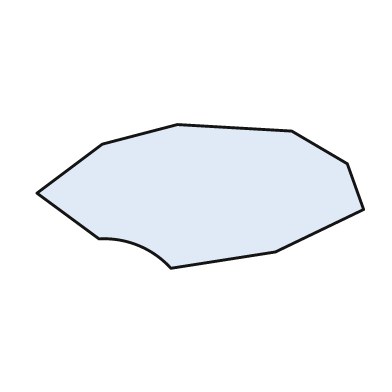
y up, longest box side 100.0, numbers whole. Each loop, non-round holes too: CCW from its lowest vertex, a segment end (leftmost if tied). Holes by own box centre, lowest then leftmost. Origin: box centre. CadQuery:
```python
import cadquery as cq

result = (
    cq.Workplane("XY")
    .moveTo(-9.0, -22.0)
    .lineTo(23.0, -17.0)
    .lineTo(50.0, -4.0)
    .lineTo(45.0, 10.0)
    .lineTo(28.0, 20.0)
    .lineTo(-7.0, 22.0)
    .lineTo(-30.0, 16.0)
    .lineTo(-50.0, 1.0)
    .lineTo(-31.0, -13.0)
    .threePointArc((-19.0, -15.0), (-9.0, -22.0))
    .close()
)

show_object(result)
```